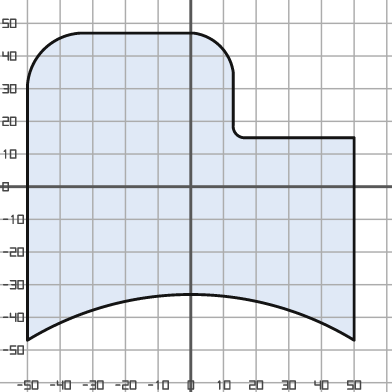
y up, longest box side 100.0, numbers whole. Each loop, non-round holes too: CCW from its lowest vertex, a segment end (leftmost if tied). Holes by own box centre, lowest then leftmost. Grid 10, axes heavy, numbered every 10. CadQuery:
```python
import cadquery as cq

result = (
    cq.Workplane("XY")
    .moveTo(-50.0, -47.0)
    .threePointArc((0.0, -33.0), (50.0, -47.0))
    .lineTo(50.0, 15.0)
    .lineTo(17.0, 15.0)
    .threePointArc((14.0, 16.0), (13.0, 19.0))
    .lineTo(13.0, 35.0)
    .threePointArc((9.0, 43.0), (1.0, 47.0))
    .lineTo(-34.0, 47.0)
    .threePointArc((-45.0, 42.0), (-50.0, 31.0))
    .close()
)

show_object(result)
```